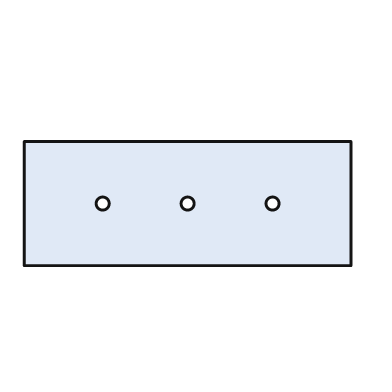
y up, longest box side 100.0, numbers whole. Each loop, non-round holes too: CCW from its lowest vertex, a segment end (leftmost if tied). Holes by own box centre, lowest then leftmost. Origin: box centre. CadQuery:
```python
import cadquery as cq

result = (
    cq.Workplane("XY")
    .moveTo(-50.0, -19.0)
    .lineTo(50.0, -19.0)
    .lineTo(50.0, 19.0)
    .lineTo(-50.0, 19.0)
    .close()
    .moveTo(-26.0, 0.0)
    .circle(2.0)
    .moveTo(0.0, 0.0)
    .circle(2.0)
    .moveTo(26.0, 0.0)
    .circle(2.0)
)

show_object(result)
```